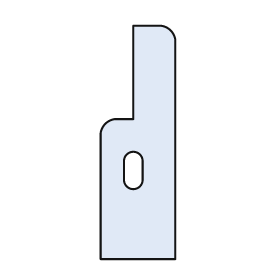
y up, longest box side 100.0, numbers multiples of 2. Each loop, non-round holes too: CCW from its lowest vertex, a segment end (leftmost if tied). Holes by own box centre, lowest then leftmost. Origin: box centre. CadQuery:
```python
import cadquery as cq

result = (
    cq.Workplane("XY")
    .moveTo(-16.0, -50.0)
    .lineTo(16.0, -50.0)
    .lineTo(16.0, 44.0)
    .threePointArc((14.0, 48.0), (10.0, 50.0))
    .lineTo(-2.0, 50.0)
    .lineTo(-2.0, 10.0)
    .lineTo(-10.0, 10.0)
    .threePointArc((-14.0, 8.0), (-16.0, 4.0))
    .close()
    .moveTo(-6.0, -16.0)
    .threePointArc((-2.0, -20.0), (2.0, -16.0))
    .lineTo(2.0, -8.0)
    .threePointArc((-2.0, -4.0), (-6.0, -8.0))
    .close()
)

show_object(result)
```